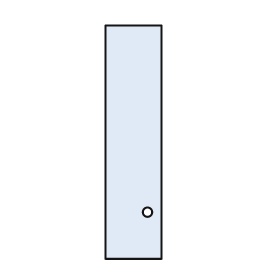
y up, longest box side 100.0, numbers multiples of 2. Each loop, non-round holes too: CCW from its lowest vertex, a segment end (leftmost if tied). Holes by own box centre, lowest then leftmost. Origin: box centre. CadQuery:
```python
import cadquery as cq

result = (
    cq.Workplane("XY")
    .moveTo(-12.0, -50.0)
    .lineTo(12.0, -50.0)
    .lineTo(12.0, 50.0)
    .lineTo(-12.0, 50.0)
    .close()
    .moveTo(6.0, -30.0)
    .circle(2.0)
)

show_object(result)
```